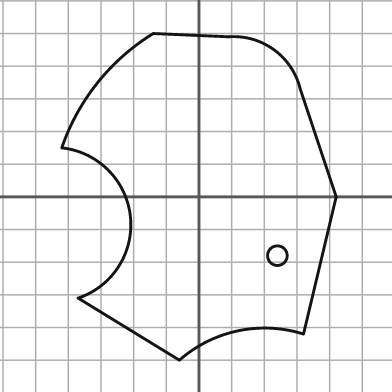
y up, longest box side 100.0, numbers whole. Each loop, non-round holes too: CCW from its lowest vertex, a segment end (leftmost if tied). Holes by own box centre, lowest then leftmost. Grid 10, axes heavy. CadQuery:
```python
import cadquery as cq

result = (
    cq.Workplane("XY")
    .moveTo(-6.0, -50.0)
    .threePointArc((12.0, -41.0), (32.0, -42.0))
    .lineTo(42.0, 0.0)
    .lineTo(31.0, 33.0)
    .threePointArc((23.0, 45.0), (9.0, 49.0))
    .lineTo(-14.0, 50.0)
    .threePointArc((-31.0, 35.0), (-42.0, 15.0))
    .threePointArc((-21.0, -6.0), (-37.0, -31.0))
    .close()
    .moveTo(24.0, -18.0)
    .circle(3.0)
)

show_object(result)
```